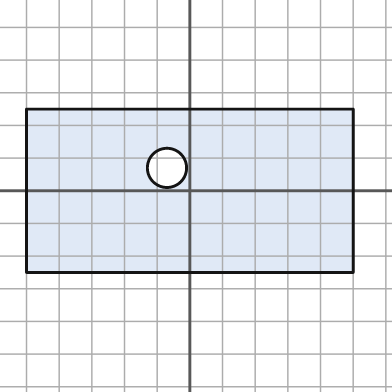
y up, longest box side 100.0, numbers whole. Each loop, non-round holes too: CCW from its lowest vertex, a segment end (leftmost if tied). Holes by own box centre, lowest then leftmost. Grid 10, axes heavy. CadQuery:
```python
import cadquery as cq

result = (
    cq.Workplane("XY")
    .moveTo(-50.0, -25.0)
    .lineTo(50.0, -25.0)
    .lineTo(50.0, 25.0)
    .lineTo(-50.0, 25.0)
    .close()
    .moveTo(-7.0, 7.0)
    .circle(6.0)
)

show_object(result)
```